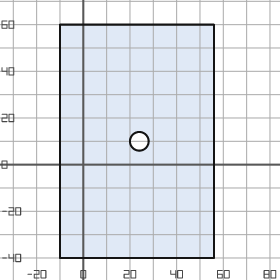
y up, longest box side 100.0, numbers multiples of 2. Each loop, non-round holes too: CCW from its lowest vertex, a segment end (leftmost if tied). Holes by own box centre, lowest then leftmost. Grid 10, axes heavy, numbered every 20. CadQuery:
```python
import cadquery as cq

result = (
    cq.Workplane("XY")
    .moveTo(-10.0, -40.0)
    .lineTo(56.0, -40.0)
    .lineTo(56.0, 60.0)
    .lineTo(-10.0, 60.0)
    .close()
    .moveTo(24.0, 10.0)
    .circle(4.0)
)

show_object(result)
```